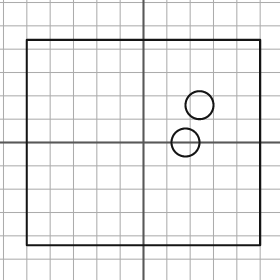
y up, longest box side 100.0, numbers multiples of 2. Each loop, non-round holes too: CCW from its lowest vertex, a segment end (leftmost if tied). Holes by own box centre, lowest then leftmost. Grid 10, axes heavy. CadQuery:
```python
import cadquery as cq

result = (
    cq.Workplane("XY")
    .moveTo(-50.0, -44.0)
    .lineTo(50.0, -44.0)
    .lineTo(50.0, 44.0)
    .lineTo(-50.0, 44.0)
    .close()
    .moveTo(18.0, 0.0)
    .circle(6.0)
    .moveTo(24.0, 16.0)
    .circle(6.0)
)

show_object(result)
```